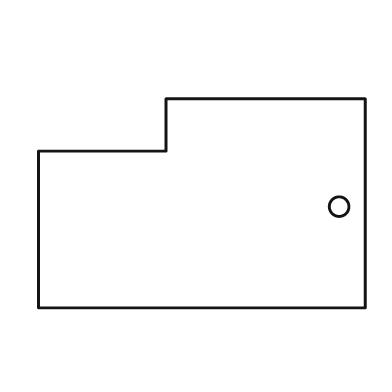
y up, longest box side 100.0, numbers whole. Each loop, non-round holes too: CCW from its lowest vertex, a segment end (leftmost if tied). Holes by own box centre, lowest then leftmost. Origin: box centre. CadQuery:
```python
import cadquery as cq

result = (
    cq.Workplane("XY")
    .moveTo(-50.0, -32.0)
    .lineTo(50.0, -32.0)
    .lineTo(50.0, 32.0)
    .lineTo(-11.0, 32.0)
    .lineTo(-11.0, 16.0)
    .lineTo(-50.0, 16.0)
    .close()
    .moveTo(42.0, -1.0)
    .circle(3.0)
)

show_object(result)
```